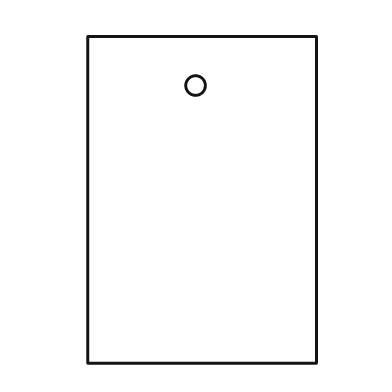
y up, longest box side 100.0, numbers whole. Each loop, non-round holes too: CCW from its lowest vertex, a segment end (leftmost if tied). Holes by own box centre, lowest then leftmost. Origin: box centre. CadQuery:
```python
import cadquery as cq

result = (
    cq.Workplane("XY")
    .moveTo(-35.0, -50.0)
    .lineTo(35.0, -50.0)
    .lineTo(35.0, 50.0)
    .lineTo(-35.0, 50.0)
    .close()
    .moveTo(-2.0, 35.0)
    .circle(3.0)
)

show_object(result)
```